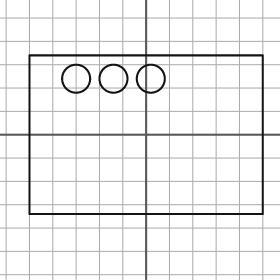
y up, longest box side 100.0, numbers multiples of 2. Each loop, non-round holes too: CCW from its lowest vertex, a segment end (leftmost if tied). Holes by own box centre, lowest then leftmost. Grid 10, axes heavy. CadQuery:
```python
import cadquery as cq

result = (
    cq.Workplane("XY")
    .moveTo(-50.0, -34.0)
    .lineTo(50.0, -34.0)
    .lineTo(50.0, 34.0)
    .lineTo(-50.0, 34.0)
    .close()
    .moveTo(-30.0, 24.0)
    .circle(6.0)
    .moveTo(-14.0, 24.0)
    .circle(6.0)
    .moveTo(2.0, 24.0)
    .circle(6.0)
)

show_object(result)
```